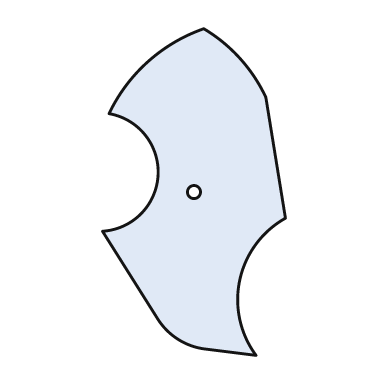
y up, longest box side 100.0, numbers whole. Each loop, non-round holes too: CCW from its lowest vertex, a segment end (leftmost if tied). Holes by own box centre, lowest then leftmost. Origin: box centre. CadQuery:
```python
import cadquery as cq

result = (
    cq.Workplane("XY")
    .moveTo(19.0, -50.0)
    .threePointArc((14.0, -27.0), (28.0, -8.0))
    .lineTo(22.0, 29.0)
    .threePointArc((14.0, 41.0), (3.0, 50.0))
    .threePointArc((-14.0, 40.0), (-26.0, 24.0))
    .threePointArc((-11.0, 5.0), (-28.0, -12.0))
    .lineTo(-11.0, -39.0)
    .threePointArc((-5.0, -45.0), (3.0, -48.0))
    .close()
    .moveTo(0.0, 0.0)
    .circle(2.0)
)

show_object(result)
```